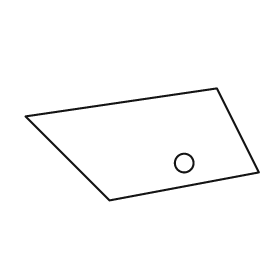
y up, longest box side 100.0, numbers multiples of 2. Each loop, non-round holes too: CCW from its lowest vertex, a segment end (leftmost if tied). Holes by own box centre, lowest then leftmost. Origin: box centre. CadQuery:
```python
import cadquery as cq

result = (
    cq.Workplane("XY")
    .moveTo(-14.0, -24.0)
    .lineTo(50.0, -12.0)
    .lineTo(32.0, 24.0)
    .lineTo(-50.0, 12.0)
    .close()
    .moveTo(18.0, -8.0)
    .circle(4.0)
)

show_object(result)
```